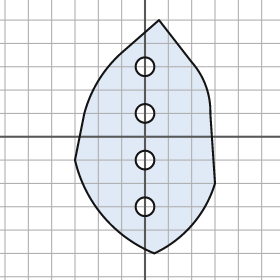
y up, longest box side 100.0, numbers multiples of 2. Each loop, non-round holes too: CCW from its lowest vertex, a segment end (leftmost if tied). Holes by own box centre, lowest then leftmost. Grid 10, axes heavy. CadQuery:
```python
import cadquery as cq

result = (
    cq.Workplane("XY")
    .moveTo(4.0, -50.0)
    .threePointArc((20.0, -38.0), (30.0, -20.0))
    .lineTo(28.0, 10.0)
    .threePointArc((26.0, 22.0), (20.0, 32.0))
    .lineTo(6.0, 50.0)
    .lineTo(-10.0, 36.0)
    .threePointArc((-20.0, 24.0), (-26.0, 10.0))
    .lineTo(-30.0, -10.0)
    .threePointArc((-18.0, -34.0), (4.0, -50.0))
    .close()
    .moveTo(0.0, -30.0)
    .circle(4.0)
    .moveTo(0.0, -10.0)
    .circle(4.0)
    .moveTo(0.0, 10.0)
    .circle(4.0)
    .moveTo(0.0, 30.0)
    .circle(4.0)
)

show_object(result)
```